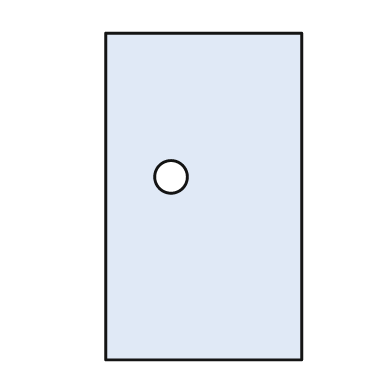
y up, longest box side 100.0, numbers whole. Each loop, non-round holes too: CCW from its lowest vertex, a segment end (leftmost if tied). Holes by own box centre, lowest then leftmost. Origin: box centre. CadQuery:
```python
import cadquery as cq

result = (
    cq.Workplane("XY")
    .moveTo(-30.0, -50.0)
    .lineTo(30.0, -50.0)
    .lineTo(30.0, 50.0)
    .lineTo(-30.0, 50.0)
    .close()
    .moveTo(-10.0, 6.0)
    .circle(5.0)
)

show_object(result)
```